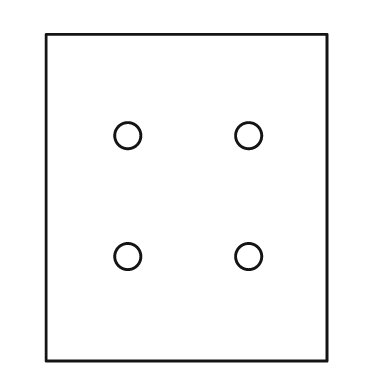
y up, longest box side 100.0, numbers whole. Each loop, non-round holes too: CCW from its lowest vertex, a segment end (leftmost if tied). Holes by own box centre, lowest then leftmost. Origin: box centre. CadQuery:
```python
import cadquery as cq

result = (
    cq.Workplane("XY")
    .moveTo(-43.0, -50.0)
    .lineTo(43.0, -50.0)
    .lineTo(43.0, 50.0)
    .lineTo(-43.0, 50.0)
    .close()
    .moveTo(-18.0, -18.0)
    .circle(4.0)
    .moveTo(19.0, -18.0)
    .circle(4.0)
    .moveTo(-18.0, 19.0)
    .circle(4.0)
    .moveTo(19.0, 19.0)
    .circle(4.0)
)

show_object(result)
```